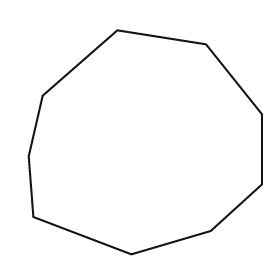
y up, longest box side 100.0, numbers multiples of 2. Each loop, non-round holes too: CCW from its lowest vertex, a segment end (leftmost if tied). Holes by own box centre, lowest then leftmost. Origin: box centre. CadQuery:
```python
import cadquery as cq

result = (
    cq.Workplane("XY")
    .moveTo(-6.0, -48.0)
    .lineTo(28.0, -38.0)
    .lineTo(50.0, -18.0)
    .lineTo(50.0, 12.0)
    .lineTo(26.0, 42.0)
    .lineTo(-12.0, 48.0)
    .lineTo(-44.0, 20.0)
    .lineTo(-50.0, -6.0)
    .lineTo(-48.0, -32.0)
    .close()
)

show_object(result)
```